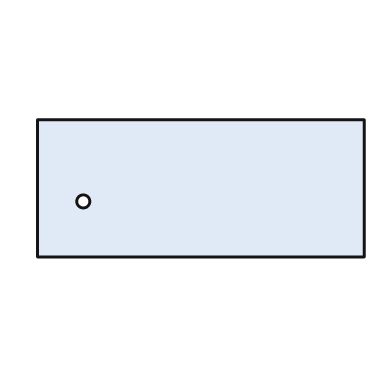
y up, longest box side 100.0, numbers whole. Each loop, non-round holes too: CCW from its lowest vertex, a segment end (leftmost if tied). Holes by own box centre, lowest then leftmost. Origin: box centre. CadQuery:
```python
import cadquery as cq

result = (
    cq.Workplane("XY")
    .moveTo(-50.0, -21.0)
    .lineTo(50.0, -21.0)
    .lineTo(50.0, 21.0)
    .lineTo(-50.0, 21.0)
    .close()
    .moveTo(-36.0, -4.0)
    .circle(2.0)
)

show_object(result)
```